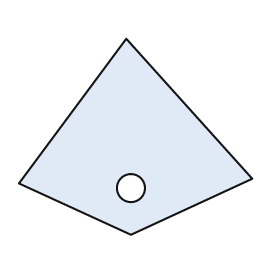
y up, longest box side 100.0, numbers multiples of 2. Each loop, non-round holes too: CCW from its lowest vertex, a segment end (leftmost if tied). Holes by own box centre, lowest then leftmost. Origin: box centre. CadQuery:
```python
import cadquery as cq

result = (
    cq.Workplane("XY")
    .moveTo(-2.0, -42.0)
    .lineTo(50.0, -18.0)
    .lineTo(-4.0, 42.0)
    .lineTo(-50.0, -20.0)
    .close()
    .moveTo(-2.0, -22.0)
    .circle(6.0)
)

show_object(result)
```